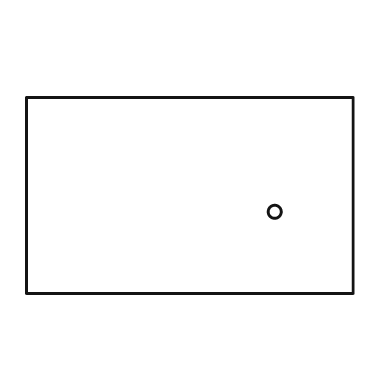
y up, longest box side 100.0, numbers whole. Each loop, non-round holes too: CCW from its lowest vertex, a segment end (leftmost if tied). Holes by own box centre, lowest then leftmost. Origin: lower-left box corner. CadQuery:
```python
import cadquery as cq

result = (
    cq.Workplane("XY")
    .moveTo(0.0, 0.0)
    .lineTo(100.0, 0.0)
    .lineTo(100.0, 60.0)
    .lineTo(0.0, 60.0)
    .close()
    .moveTo(76.0, 25.0)
    .circle(2.0)
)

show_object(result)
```